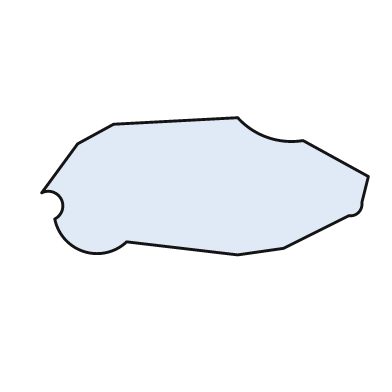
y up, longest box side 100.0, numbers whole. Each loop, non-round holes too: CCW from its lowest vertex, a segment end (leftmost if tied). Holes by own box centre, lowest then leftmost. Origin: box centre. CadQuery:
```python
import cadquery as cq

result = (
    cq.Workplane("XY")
    .moveTo(10.0, -21.0)
    .lineTo(24.0, -19.0)
    .lineTo(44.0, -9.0)
    .threePointArc((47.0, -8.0), (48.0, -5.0))
    .lineTo(50.0, 3.0)
    .lineTo(30.0, 14.0)
    .threePointArc((19.0, 15.0), (10.0, 21.0))
    .lineTo(-28.0, 19.0)
    .lineTo(-39.0, 13.0)
    .lineTo(-50.0, -2.0)
    .threePointArc((-44.0, -4.0), (-46.0, -10.0))
    .threePointArc((-37.0, -20.0), (-24.0, -17.0))
    .close()
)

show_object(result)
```